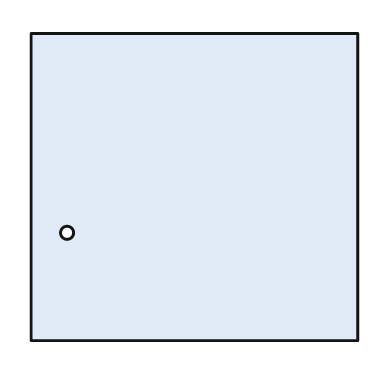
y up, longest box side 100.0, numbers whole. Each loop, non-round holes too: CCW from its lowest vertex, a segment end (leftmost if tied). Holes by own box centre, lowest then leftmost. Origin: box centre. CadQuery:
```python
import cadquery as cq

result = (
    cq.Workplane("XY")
    .moveTo(-50.0, -47.0)
    .lineTo(50.0, -47.0)
    .lineTo(50.0, 47.0)
    .lineTo(-50.0, 47.0)
    .close()
    .moveTo(-39.0, -14.0)
    .circle(2.0)
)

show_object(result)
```